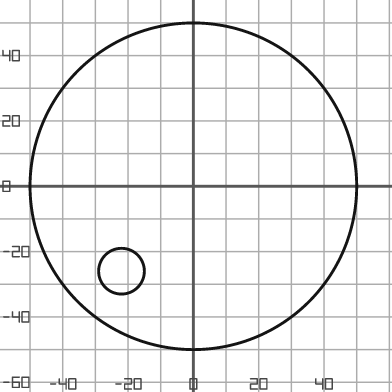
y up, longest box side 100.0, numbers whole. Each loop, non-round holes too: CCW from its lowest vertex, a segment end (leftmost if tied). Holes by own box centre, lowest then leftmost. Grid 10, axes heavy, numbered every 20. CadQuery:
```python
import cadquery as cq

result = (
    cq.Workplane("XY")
    .moveTo(0.0, 0.0)
    .circle(50.0)
    .moveTo(-22.0, -26.0)
    .circle(7.0)
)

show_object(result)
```